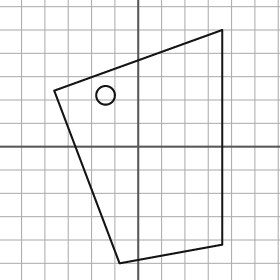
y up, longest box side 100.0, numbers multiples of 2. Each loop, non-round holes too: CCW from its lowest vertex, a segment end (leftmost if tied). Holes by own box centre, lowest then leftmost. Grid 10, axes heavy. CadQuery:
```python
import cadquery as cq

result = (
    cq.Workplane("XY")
    .moveTo(-8.0, -50.0)
    .lineTo(36.0, -42.0)
    .lineTo(36.0, 50.0)
    .lineTo(-36.0, 24.0)
    .close()
    .moveTo(-14.0, 22.0)
    .circle(4.0)
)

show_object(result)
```